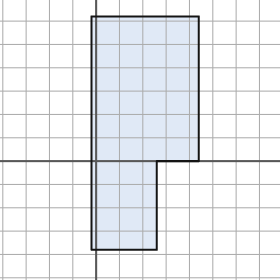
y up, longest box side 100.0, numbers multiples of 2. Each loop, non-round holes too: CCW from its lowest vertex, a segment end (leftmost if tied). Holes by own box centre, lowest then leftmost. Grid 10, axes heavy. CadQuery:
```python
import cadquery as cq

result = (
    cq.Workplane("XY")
    .moveTo(-2.0, -38.0)
    .lineTo(26.0, -38.0)
    .lineTo(26.0, 0.0)
    .lineTo(44.0, 0.0)
    .lineTo(44.0, 62.0)
    .lineTo(-2.0, 62.0)
    .close()
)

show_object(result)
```